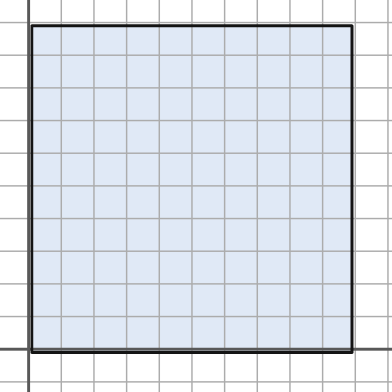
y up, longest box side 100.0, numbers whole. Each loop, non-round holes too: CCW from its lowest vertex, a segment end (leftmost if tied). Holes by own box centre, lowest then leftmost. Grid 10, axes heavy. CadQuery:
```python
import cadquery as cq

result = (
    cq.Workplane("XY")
    .moveTo(1.0, -1.0)
    .lineTo(99.0, -1.0)
    .lineTo(99.0, 99.0)
    .lineTo(1.0, 99.0)
    .close()
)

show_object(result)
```